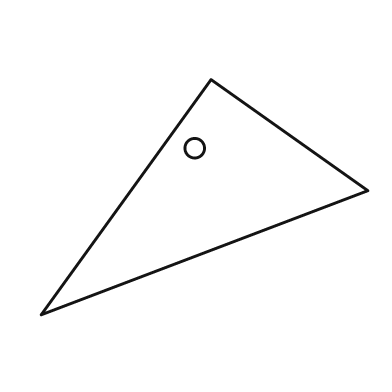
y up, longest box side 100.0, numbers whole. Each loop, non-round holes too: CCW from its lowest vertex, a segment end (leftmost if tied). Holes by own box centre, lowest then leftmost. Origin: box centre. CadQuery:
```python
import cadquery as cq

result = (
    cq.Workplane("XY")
    .moveTo(-50.0, -36.0)
    .lineTo(50.0, 2.0)
    .lineTo(2.0, 36.0)
    .close()
    .moveTo(-3.0, 15.0)
    .circle(3.0)
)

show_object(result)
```